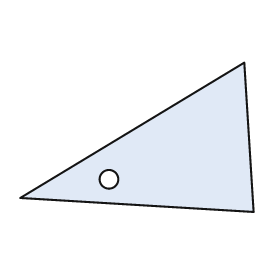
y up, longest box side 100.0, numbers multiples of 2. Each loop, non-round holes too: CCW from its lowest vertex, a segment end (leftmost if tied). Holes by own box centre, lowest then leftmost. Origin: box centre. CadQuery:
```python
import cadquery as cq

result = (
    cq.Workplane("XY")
    .moveTo(50.0, -32.0)
    .lineTo(46.0, 32.0)
    .lineTo(-50.0, -26.0)
    .close()
    .moveTo(-12.0, -18.0)
    .circle(4.0)
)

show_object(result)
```